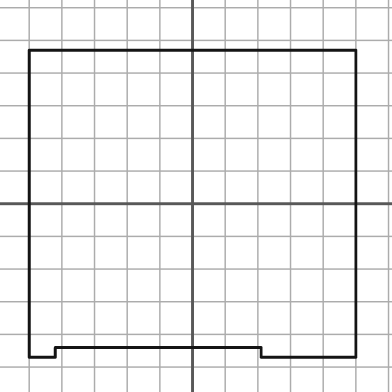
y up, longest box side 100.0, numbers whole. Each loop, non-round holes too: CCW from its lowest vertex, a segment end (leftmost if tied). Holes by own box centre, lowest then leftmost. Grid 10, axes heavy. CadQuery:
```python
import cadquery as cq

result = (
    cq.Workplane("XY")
    .moveTo(-50.0, -47.0)
    .lineTo(-42.0, -47.0)
    .lineTo(-42.0, -44.0)
    .lineTo(21.0, -44.0)
    .lineTo(21.0, -47.0)
    .lineTo(50.0, -47.0)
    .lineTo(50.0, 47.0)
    .lineTo(-50.0, 47.0)
    .close()
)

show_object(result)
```